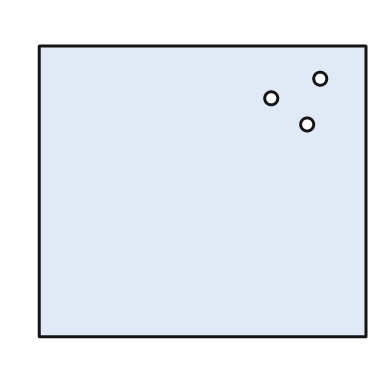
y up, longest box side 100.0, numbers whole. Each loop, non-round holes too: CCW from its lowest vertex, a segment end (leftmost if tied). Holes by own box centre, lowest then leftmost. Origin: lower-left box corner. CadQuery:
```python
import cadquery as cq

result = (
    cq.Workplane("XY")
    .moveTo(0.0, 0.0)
    .lineTo(100.0, 0.0)
    .lineTo(100.0, 89.0)
    .lineTo(0.0, 89.0)
    .close()
    .moveTo(82.0, 65.0)
    .circle(2.0)
    .moveTo(71.0, 73.0)
    .circle(2.0)
    .moveTo(86.0, 79.0)
    .circle(2.0)
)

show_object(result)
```